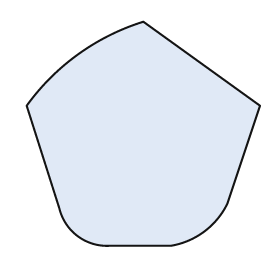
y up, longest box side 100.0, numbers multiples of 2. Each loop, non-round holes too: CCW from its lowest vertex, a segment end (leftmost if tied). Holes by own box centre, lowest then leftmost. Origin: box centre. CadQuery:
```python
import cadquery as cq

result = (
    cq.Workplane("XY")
    .moveTo(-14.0, -48.0)
    .lineTo(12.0, -48.0)
    .threePointArc((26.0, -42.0), (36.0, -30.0))
    .lineTo(50.0, 12.0)
    .lineTo(0.0, 48.0)
    .threePointArc((-28.0, 34.0), (-50.0, 12.0))
    .lineTo(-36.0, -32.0)
    .threePointArc((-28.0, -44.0), (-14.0, -48.0))
    .close()
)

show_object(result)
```